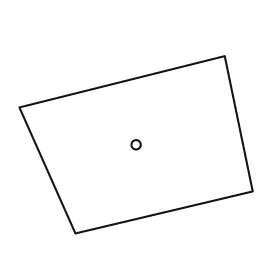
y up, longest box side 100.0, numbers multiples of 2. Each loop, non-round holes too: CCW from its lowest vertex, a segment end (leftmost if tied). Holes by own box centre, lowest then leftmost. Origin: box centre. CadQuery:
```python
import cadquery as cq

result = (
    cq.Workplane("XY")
    .moveTo(-26.0, -38.0)
    .lineTo(50.0, -20.0)
    .lineTo(38.0, 38.0)
    .lineTo(-50.0, 16.0)
    .close()
    .moveTo(0.0, 0.0)
    .circle(2.0)
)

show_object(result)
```